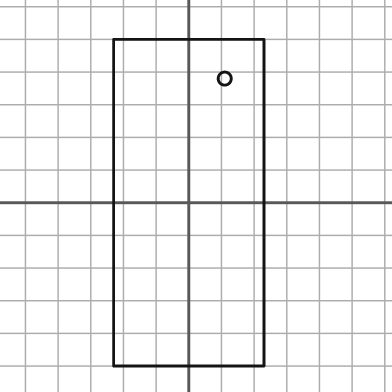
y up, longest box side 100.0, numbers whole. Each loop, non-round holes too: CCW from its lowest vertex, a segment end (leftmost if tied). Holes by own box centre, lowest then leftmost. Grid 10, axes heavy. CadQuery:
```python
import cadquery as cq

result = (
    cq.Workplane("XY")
    .moveTo(-23.0, -50.0)
    .lineTo(23.0, -50.0)
    .lineTo(23.0, 50.0)
    .lineTo(-23.0, 50.0)
    .close()
    .moveTo(11.0, 38.0)
    .circle(2.0)
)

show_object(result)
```